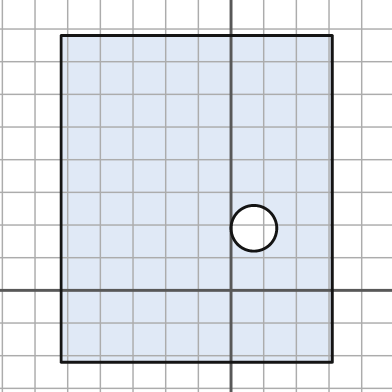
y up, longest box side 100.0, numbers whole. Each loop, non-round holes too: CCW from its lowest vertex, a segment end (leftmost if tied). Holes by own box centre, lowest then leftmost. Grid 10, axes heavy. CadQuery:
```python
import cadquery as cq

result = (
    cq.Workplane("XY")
    .moveTo(-52.0, -22.0)
    .lineTo(31.0, -22.0)
    .lineTo(31.0, 78.0)
    .lineTo(-52.0, 78.0)
    .close()
    .moveTo(7.0, 19.0)
    .circle(7.0)
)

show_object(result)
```